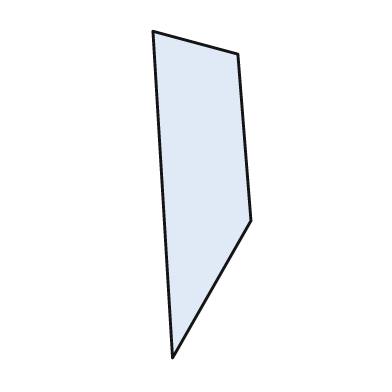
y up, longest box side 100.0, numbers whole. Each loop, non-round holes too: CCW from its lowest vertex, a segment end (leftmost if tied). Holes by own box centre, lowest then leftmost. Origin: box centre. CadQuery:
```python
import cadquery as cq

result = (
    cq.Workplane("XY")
    .moveTo(-9.0, -50.0)
    .lineTo(15.0, -8.0)
    .lineTo(11.0, 43.0)
    .lineTo(-15.0, 50.0)
    .close()
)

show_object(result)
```